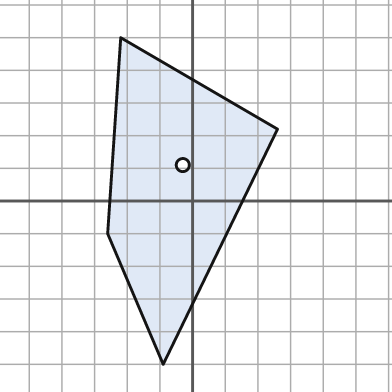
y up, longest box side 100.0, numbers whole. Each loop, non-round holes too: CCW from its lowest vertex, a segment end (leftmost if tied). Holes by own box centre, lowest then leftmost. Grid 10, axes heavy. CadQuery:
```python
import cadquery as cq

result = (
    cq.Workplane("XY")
    .moveTo(-9.0, -50.0)
    .lineTo(26.0, 22.0)
    .lineTo(-22.0, 50.0)
    .lineTo(-26.0, -10.0)
    .close()
    .moveTo(-3.0, 11.0)
    .circle(2.0)
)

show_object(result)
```